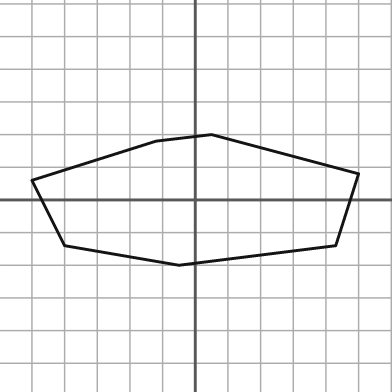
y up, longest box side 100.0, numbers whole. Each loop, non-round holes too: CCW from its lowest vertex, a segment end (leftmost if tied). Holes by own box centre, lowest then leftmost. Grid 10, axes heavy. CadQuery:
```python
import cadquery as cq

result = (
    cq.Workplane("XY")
    .moveTo(-5.0, -20.0)
    .lineTo(43.0, -14.0)
    .lineTo(50.0, 8.0)
    .lineTo(5.0, 20.0)
    .lineTo(-12.0, 18.0)
    .lineTo(-50.0, 6.0)
    .lineTo(-40.0, -14.0)
    .close()
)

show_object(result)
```